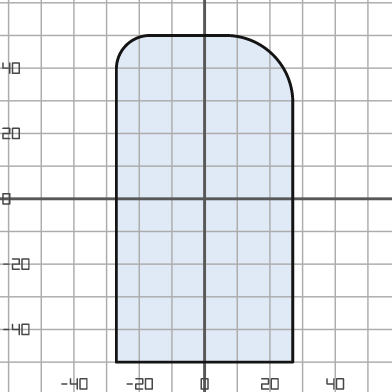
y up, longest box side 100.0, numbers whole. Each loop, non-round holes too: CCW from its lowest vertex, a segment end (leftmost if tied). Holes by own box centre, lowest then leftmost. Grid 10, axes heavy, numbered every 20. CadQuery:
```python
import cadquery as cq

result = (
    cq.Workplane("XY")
    .moveTo(-27.0, -50.0)
    .lineTo(27.0, -50.0)
    .lineTo(27.0, 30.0)
    .threePointArc((21.0, 44.0), (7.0, 50.0))
    .lineTo(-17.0, 50.0)
    .threePointArc((-24.0, 47.0), (-27.0, 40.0))
    .close()
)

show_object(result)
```